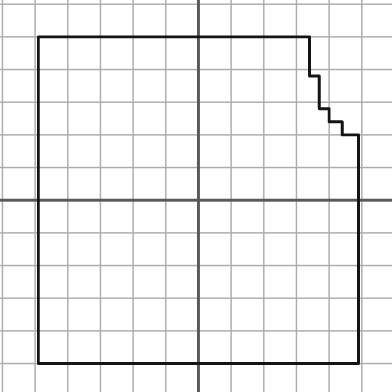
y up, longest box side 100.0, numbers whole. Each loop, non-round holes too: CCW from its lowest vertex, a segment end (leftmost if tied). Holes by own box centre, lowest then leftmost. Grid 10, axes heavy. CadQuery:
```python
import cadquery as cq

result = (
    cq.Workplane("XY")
    .moveTo(-49.0, -50.0)
    .lineTo(49.0, -50.0)
    .lineTo(49.0, 20.0)
    .lineTo(44.0, 20.0)
    .lineTo(44.0, 24.0)
    .lineTo(40.0, 24.0)
    .lineTo(40.0, 28.0)
    .lineTo(37.0, 28.0)
    .lineTo(37.0, 38.0)
    .lineTo(34.0, 38.0)
    .lineTo(34.0, 50.0)
    .lineTo(-49.0, 50.0)
    .close()
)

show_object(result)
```